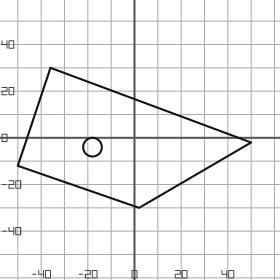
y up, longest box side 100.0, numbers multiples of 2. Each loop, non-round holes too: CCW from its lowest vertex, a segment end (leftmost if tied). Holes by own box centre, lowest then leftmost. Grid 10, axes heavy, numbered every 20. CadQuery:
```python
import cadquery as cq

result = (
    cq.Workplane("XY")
    .moveTo(2.0, -30.0)
    .lineTo(50.0, -2.0)
    .lineTo(-36.0, 30.0)
    .lineTo(-50.0, -12.0)
    .close()
    .moveTo(-18.0, -4.0)
    .circle(4.0)
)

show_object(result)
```